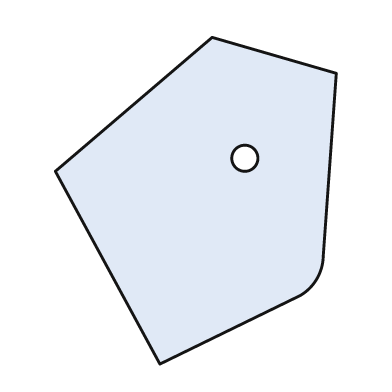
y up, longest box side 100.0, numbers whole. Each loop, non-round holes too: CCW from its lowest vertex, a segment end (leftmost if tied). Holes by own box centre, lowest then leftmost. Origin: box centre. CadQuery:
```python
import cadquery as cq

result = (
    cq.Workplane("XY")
    .moveTo(-11.0, -50.0)
    .lineTo(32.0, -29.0)
    .threePointArc((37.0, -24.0), (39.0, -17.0))
    .lineTo(43.0, 39.0)
    .lineTo(5.0, 50.0)
    .lineTo(-43.0, 9.0)
    .close()
    .moveTo(15.0, 13.0)
    .circle(4.0)
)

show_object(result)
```